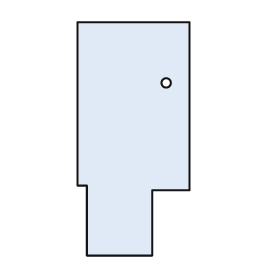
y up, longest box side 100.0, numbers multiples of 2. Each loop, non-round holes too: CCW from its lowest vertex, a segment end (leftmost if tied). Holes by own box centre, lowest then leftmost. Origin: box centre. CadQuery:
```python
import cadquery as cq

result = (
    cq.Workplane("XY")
    .moveTo(-20.0, -50.0)
    .lineTo(8.0, -50.0)
    .lineTo(8.0, -22.0)
    .lineTo(24.0, -22.0)
    .lineTo(24.0, 50.0)
    .lineTo(-24.0, 50.0)
    .lineTo(-24.0, -20.0)
    .lineTo(-20.0, -20.0)
    .close()
    .moveTo(14.0, 24.0)
    .circle(2.0)
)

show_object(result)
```